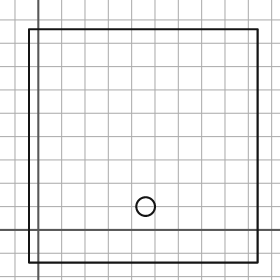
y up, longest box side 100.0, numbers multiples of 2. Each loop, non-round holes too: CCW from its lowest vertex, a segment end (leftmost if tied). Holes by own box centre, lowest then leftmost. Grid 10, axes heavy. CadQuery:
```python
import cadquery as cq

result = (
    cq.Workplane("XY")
    .moveTo(-4.0, -14.0)
    .lineTo(94.0, -14.0)
    .lineTo(94.0, 86.0)
    .lineTo(-4.0, 86.0)
    .close()
    .moveTo(46.0, 10.0)
    .circle(4.0)
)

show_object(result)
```